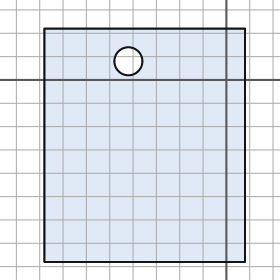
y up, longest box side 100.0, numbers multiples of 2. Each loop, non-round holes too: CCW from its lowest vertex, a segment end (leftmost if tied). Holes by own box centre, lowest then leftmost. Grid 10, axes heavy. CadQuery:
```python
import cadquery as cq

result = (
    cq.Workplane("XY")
    .moveTo(-78.0, -78.0)
    .lineTo(8.0, -78.0)
    .lineTo(8.0, 22.0)
    .lineTo(-78.0, 22.0)
    .close()
    .moveTo(-42.0, 8.0)
    .circle(6.0)
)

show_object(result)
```